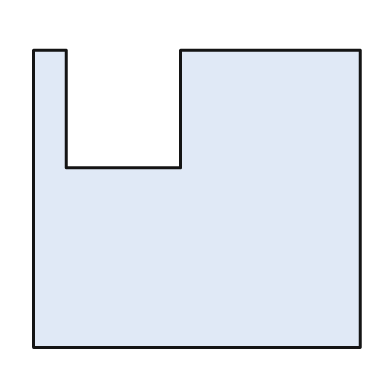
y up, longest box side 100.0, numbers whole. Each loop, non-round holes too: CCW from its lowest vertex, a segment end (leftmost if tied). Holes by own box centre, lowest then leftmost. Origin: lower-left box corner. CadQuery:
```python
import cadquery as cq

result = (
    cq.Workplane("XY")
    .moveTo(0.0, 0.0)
    .lineTo(100.0, 0.0)
    .lineTo(100.0, 91.0)
    .lineTo(45.0, 91.0)
    .lineTo(45.0, 55.0)
    .lineTo(10.0, 55.0)
    .lineTo(10.0, 91.0)
    .lineTo(0.0, 91.0)
    .close()
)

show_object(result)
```